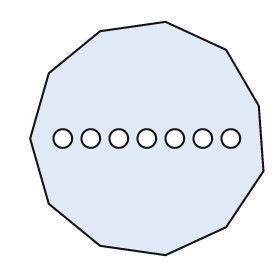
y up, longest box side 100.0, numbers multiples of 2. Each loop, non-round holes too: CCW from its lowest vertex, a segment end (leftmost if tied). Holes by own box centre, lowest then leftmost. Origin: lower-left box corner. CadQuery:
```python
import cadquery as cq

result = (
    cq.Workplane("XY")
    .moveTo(58.0, 0.0)
    .lineTo(84.0, 12.0)
    .lineTo(100.0, 36.0)
    .lineTo(98.0, 64.0)
    .lineTo(84.0, 88.0)
    .lineTo(58.0, 100.0)
    .lineTo(30.0, 96.0)
    .lineTo(8.0, 78.0)
    .lineTo(0.0, 50.0)
    .lineTo(8.0, 22.0)
    .lineTo(30.0, 4.0)
    .close()
    .moveTo(14.0, 50.0)
    .circle(4.0)
    .moveTo(26.0, 50.0)
    .circle(4.0)
    .moveTo(38.0, 50.0)
    .circle(4.0)
    .moveTo(50.0, 50.0)
    .circle(4.0)
    .moveTo(62.0, 50.0)
    .circle(4.0)
    .moveTo(74.0, 50.0)
    .circle(4.0)
    .moveTo(86.0, 50.0)
    .circle(4.0)
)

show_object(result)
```